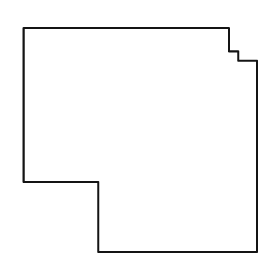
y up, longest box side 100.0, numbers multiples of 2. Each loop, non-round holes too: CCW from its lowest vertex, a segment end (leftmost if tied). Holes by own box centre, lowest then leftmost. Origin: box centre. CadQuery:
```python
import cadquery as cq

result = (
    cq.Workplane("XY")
    .moveTo(-18.0, -48.0)
    .lineTo(50.0, -48.0)
    .lineTo(50.0, 34.0)
    .lineTo(42.0, 34.0)
    .lineTo(42.0, 38.0)
    .lineTo(38.0, 38.0)
    .lineTo(38.0, 48.0)
    .lineTo(-50.0, 48.0)
    .lineTo(-50.0, -18.0)
    .lineTo(-18.0, -18.0)
    .close()
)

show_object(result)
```